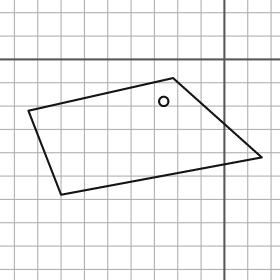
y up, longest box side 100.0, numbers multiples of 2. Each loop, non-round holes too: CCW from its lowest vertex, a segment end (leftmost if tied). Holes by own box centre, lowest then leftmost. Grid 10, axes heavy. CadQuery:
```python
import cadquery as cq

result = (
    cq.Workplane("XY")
    .moveTo(-70.0, -58.0)
    .lineTo(16.0, -42.0)
    .lineTo(-22.0, -8.0)
    .lineTo(-84.0, -22.0)
    .close()
    .moveTo(-26.0, -18.0)
    .circle(2.0)
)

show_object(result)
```